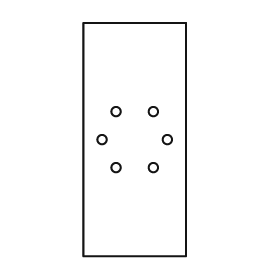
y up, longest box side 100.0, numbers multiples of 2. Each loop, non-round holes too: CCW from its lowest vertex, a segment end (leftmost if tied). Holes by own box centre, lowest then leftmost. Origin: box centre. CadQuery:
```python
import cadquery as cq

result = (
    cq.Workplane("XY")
    .moveTo(-22.0, -50.0)
    .lineTo(22.0, -50.0)
    .lineTo(22.0, 50.0)
    .lineTo(-22.0, 50.0)
    .close()
    .moveTo(-8.0, -12.0)
    .circle(2.0)
    .moveTo(8.0, -12.0)
    .circle(2.0)
    .moveTo(-14.0, 0.0)
    .circle(2.0)
    .moveTo(14.0, 0.0)
    .circle(2.0)
    .moveTo(-8.0, 12.0)
    .circle(2.0)
    .moveTo(8.0, 12.0)
    .circle(2.0)
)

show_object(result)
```